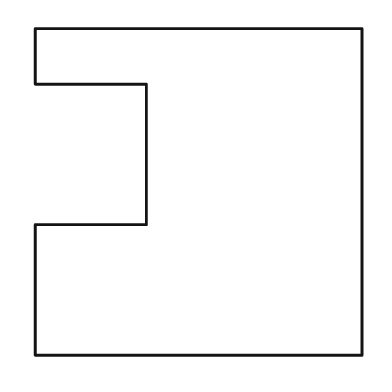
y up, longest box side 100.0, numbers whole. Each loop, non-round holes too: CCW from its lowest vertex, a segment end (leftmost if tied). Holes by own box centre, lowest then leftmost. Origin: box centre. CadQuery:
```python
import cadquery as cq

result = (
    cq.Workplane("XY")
    .moveTo(-50.0, -50.0)
    .lineTo(50.0, -50.0)
    .lineTo(50.0, 50.0)
    .lineTo(-50.0, 50.0)
    .lineTo(-50.0, 33.0)
    .lineTo(-16.0, 33.0)
    .lineTo(-16.0, -10.0)
    .lineTo(-50.0, -10.0)
    .close()
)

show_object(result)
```